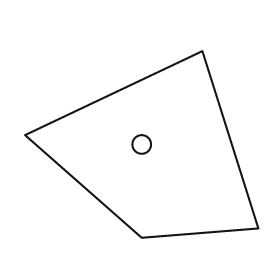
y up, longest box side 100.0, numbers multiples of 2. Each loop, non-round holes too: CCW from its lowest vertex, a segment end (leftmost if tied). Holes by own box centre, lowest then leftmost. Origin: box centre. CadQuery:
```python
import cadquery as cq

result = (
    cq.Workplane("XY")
    .moveTo(0.0, -40.0)
    .lineTo(50.0, -36.0)
    .lineTo(26.0, 40.0)
    .lineTo(-50.0, 4.0)
    .close()
    .moveTo(0.0, 0.0)
    .circle(4.0)
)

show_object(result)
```